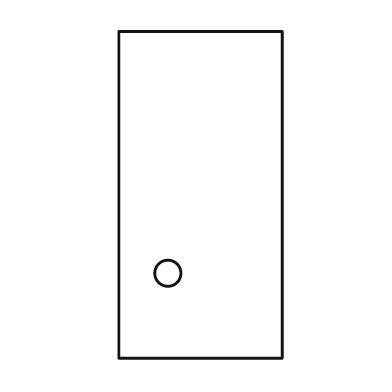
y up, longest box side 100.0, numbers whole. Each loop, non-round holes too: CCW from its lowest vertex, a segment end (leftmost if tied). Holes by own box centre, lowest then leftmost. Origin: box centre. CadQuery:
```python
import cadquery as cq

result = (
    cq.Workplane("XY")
    .moveTo(-25.0, -50.0)
    .lineTo(25.0, -50.0)
    .lineTo(25.0, 50.0)
    .lineTo(-25.0, 50.0)
    .close()
    .moveTo(-10.0, -24.0)
    .circle(4.0)
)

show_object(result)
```